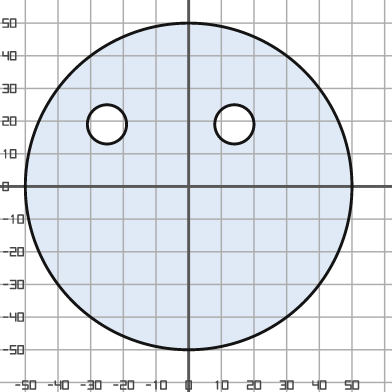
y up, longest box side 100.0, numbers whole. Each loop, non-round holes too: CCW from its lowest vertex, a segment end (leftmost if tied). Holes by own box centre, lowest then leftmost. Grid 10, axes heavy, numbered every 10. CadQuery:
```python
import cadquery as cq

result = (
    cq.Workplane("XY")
    .moveTo(0.0, 0.0)
    .circle(50.0)
    .moveTo(-25.0, 19.0)
    .circle(6.0)
    .moveTo(14.0, 19.0)
    .circle(6.0)
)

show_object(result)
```